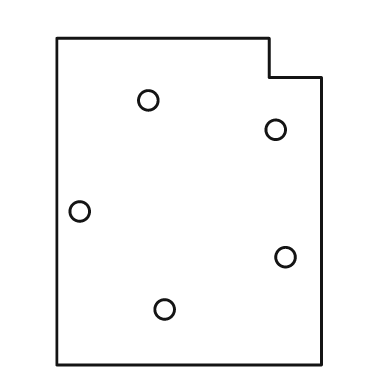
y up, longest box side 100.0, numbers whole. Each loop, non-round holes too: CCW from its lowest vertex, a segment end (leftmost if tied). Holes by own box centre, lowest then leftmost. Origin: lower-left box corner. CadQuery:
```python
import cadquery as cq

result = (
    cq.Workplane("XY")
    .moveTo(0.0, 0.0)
    .lineTo(81.0, 0.0)
    .lineTo(81.0, 88.0)
    .lineTo(65.0, 88.0)
    .lineTo(65.0, 100.0)
    .lineTo(0.0, 100.0)
    .close()
    .moveTo(33.0, 17.0)
    .circle(3.0)
    .moveTo(70.0, 33.0)
    .circle(3.0)
    .moveTo(7.0, 47.0)
    .circle(3.0)
    .moveTo(67.0, 72.0)
    .circle(3.0)
    .moveTo(28.0, 81.0)
    .circle(3.0)
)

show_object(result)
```